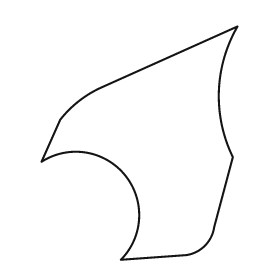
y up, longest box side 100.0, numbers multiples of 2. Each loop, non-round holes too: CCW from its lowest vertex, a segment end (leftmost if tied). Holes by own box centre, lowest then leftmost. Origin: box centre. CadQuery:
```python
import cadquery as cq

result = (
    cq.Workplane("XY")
    .moveTo(-8.0, -50.0)
    .lineTo(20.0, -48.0)
    .threePointArc((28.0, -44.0), (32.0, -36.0))
    .lineTo(40.0, -6.0)
    .threePointArc((34.0, 22.0), (42.0, 50.0))
    .lineTo(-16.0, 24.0)
    .threePointArc((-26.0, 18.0), (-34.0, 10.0))
    .lineTo(-42.0, -8.0)
    .threePointArc((-6.0, -14.0), (-8.0, -50.0))
    .close()
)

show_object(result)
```